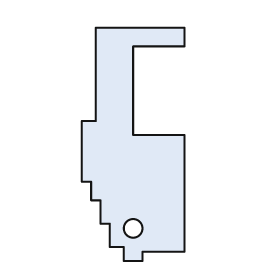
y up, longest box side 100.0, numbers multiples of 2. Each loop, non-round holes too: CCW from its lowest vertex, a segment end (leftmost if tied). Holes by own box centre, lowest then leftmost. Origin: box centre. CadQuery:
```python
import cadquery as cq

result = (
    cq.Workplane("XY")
    .moveTo(-4.0, -50.0)
    .lineTo(4.0, -50.0)
    .lineTo(4.0, -46.0)
    .lineTo(22.0, -46.0)
    .lineTo(22.0, 4.0)
    .lineTo(0.0, 4.0)
    .lineTo(0.0, 42.0)
    .lineTo(22.0, 42.0)
    .lineTo(22.0, 50.0)
    .lineTo(-16.0, 50.0)
    .lineTo(-16.0, 10.0)
    .lineTo(-22.0, 10.0)
    .lineTo(-22.0, -16.0)
    .lineTo(-18.0, -16.0)
    .lineTo(-18.0, -24.0)
    .lineTo(-14.0, -24.0)
    .lineTo(-14.0, -34.0)
    .lineTo(-10.0, -34.0)
    .lineTo(-10.0, -44.0)
    .lineTo(-4.0, -44.0)
    .close()
    .moveTo(0.0, -36.0)
    .circle(4.0)
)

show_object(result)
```